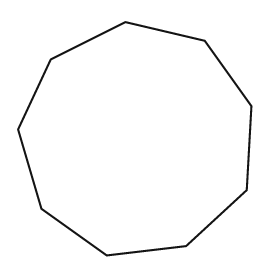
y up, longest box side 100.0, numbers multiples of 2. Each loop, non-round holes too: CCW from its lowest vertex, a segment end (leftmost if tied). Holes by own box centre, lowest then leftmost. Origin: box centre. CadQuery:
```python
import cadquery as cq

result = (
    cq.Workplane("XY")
    .moveTo(-12.0, -50.0)
    .lineTo(22.0, -46.0)
    .lineTo(48.0, -22.0)
    .lineTo(50.0, 14.0)
    .lineTo(30.0, 42.0)
    .lineTo(-4.0, 50.0)
    .lineTo(-36.0, 34.0)
    .lineTo(-50.0, 4.0)
    .lineTo(-40.0, -30.0)
    .close()
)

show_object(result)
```